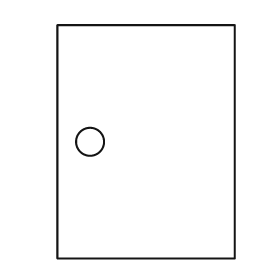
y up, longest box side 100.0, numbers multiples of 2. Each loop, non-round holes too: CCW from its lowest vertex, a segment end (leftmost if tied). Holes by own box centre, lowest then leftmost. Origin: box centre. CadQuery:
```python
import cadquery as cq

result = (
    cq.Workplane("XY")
    .moveTo(-38.0, -50.0)
    .lineTo(38.0, -50.0)
    .lineTo(38.0, 50.0)
    .lineTo(-38.0, 50.0)
    .close()
    .moveTo(-24.0, 0.0)
    .circle(6.0)
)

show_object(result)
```